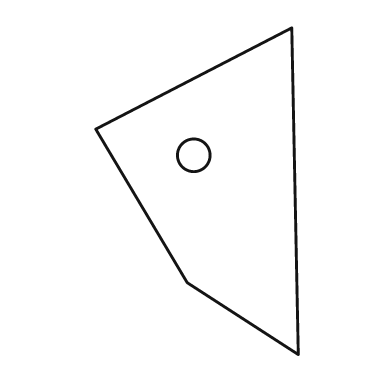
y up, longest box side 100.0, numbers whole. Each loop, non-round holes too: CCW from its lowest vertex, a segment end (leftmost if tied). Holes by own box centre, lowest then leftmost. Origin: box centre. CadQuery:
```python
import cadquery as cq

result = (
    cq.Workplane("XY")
    .moveTo(31.0, -50.0)
    .lineTo(29.0, 50.0)
    .lineTo(-31.0, 19.0)
    .lineTo(-3.0, -28.0)
    .close()
    .moveTo(-1.0, 11.0)
    .circle(5.0)
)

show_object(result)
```